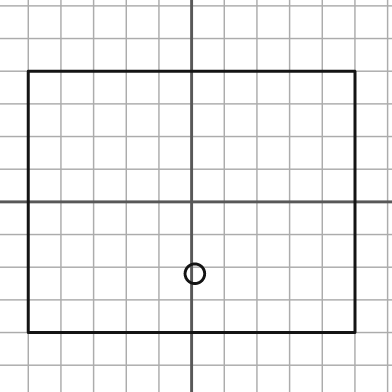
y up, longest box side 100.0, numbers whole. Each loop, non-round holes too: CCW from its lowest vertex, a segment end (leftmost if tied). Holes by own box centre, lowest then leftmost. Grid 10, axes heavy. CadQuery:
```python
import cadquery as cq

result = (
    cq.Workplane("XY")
    .moveTo(-50.0, -40.0)
    .lineTo(50.0, -40.0)
    .lineTo(50.0, 40.0)
    .lineTo(-50.0, 40.0)
    .close()
    .moveTo(1.0, -22.0)
    .circle(3.0)
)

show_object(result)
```